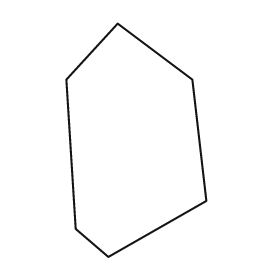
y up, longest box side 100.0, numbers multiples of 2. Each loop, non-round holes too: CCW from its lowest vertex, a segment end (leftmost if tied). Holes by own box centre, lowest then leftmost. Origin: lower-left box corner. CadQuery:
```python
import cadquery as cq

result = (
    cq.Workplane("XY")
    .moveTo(18.0, 0.0)
    .lineTo(60.0, 24.0)
    .lineTo(54.0, 76.0)
    .lineTo(22.0, 100.0)
    .lineTo(0.0, 76.0)
    .lineTo(4.0, 12.0)
    .close()
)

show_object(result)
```